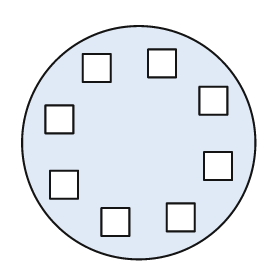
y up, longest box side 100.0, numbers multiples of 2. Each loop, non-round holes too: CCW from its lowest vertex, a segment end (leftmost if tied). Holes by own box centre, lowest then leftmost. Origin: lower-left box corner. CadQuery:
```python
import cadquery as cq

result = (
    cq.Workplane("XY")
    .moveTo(50.0, 50.0)
    .circle(50.0)
    .moveTo(34.0, 10.0)
    .lineTo(46.0, 10.0)
    .lineTo(46.0, 22.0)
    .lineTo(34.0, 22.0)
    .close()
    .moveTo(62.0, 12.0)
    .lineTo(74.0, 12.0)
    .lineTo(74.0, 24.0)
    .lineTo(62.0, 24.0)
    .close()
    .moveTo(12.0, 26.0)
    .lineTo(24.0, 26.0)
    .lineTo(24.0, 38.0)
    .lineTo(12.0, 38.0)
    .close()
    .moveTo(78.0, 34.0)
    .lineTo(90.0, 34.0)
    .lineTo(90.0, 46.0)
    .lineTo(78.0, 46.0)
    .close()
    .moveTo(10.0, 54.0)
    .lineTo(22.0, 54.0)
    .lineTo(22.0, 66.0)
    .lineTo(10.0, 66.0)
    .close()
    .moveTo(76.0, 62.0)
    .lineTo(88.0, 62.0)
    .lineTo(88.0, 74.0)
    .lineTo(76.0, 74.0)
    .close()
    .moveTo(26.0, 76.0)
    .lineTo(38.0, 76.0)
    .lineTo(38.0, 88.0)
    .lineTo(26.0, 88.0)
    .close()
    .moveTo(54.0, 78.0)
    .lineTo(66.0, 78.0)
    .lineTo(66.0, 90.0)
    .lineTo(54.0, 90.0)
    .close()
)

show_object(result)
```